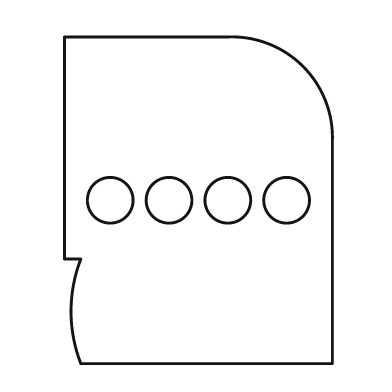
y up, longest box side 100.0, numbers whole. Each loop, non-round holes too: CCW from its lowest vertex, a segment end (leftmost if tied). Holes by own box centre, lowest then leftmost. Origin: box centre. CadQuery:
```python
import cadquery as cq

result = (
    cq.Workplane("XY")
    .moveTo(-36.0, -50.0)
    .lineTo(41.0, -50.0)
    .lineTo(41.0, 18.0)
    .threePointArc((32.0, 41.0), (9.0, 50.0))
    .lineTo(-41.0, 50.0)
    .lineTo(-41.0, -18.0)
    .lineTo(-36.0, -18.0)
    .threePointArc((-39.0, -34.0), (-36.0, -50.0))
    .close()
    .moveTo(-27.0, 0.0)
    .circle(7.0)
    .moveTo(-9.0, 0.0)
    .circle(7.0)
    .moveTo(9.0, 0.0)
    .circle(7.0)
    .moveTo(27.0, 0.0)
    .circle(7.0)
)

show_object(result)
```